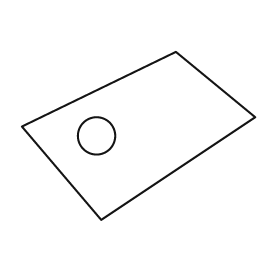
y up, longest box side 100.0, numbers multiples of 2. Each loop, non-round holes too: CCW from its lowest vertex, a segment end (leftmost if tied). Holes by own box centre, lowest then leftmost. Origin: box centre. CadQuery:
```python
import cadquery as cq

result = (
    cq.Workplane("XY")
    .moveTo(-16.0, -36.0)
    .lineTo(50.0, 8.0)
    .lineTo(16.0, 36.0)
    .lineTo(-50.0, 4.0)
    .close()
    .moveTo(-18.0, 0.0)
    .circle(8.0)
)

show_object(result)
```